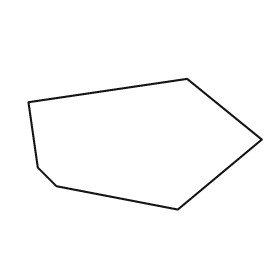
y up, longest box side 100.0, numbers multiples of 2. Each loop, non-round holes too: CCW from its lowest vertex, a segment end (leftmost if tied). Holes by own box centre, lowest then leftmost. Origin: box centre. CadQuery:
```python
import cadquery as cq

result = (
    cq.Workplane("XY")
    .moveTo(14.0, -28.0)
    .lineTo(50.0, 2.0)
    .lineTo(18.0, 28.0)
    .lineTo(-50.0, 18.0)
    .lineTo(-46.0, -10.0)
    .lineTo(-38.0, -18.0)
    .close()
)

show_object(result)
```